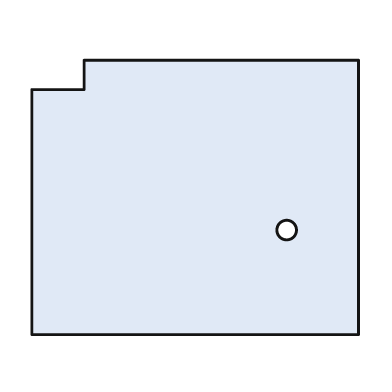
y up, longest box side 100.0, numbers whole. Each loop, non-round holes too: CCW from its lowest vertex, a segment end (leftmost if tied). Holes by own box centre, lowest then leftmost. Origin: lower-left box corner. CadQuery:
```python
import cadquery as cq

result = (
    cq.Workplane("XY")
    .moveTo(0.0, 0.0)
    .lineTo(100.0, 0.0)
    .lineTo(100.0, 84.0)
    .lineTo(16.0, 84.0)
    .lineTo(16.0, 75.0)
    .lineTo(0.0, 75.0)
    .close()
    .moveTo(78.0, 32.0)
    .circle(3.0)
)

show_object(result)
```